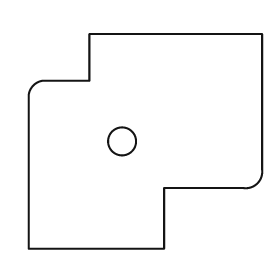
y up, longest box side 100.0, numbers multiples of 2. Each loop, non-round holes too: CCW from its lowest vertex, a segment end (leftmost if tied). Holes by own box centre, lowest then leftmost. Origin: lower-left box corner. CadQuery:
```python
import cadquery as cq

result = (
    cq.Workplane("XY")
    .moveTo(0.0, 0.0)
    .lineTo(58.0, 0.0)
    .lineTo(58.0, 26.0)
    .lineTo(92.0, 26.0)
    .threePointArc((98.0, 28.0), (100.0, 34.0))
    .lineTo(100.0, 92.0)
    .lineTo(26.0, 92.0)
    .lineTo(26.0, 72.0)
    .lineTo(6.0, 72.0)
    .threePointArc((2.0, 70.0), (0.0, 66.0))
    .close()
    .moveTo(40.0, 46.0)
    .circle(6.0)
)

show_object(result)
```